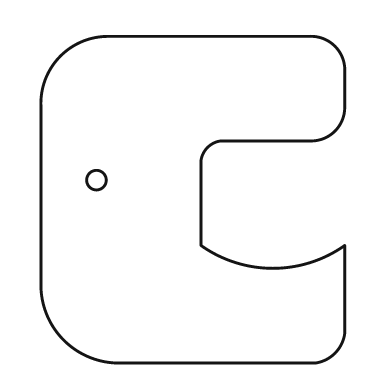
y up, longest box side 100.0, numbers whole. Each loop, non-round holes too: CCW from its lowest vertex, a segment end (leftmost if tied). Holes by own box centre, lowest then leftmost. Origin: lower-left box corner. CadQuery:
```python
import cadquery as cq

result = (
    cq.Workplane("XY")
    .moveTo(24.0, 0.0)
    .lineTo(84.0, 0.0)
    .threePointArc((90.0, 3.0), (93.0, 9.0))
    .lineTo(93.0, 36.0)
    .threePointArc((71.0, 29.0), (49.0, 36.0))
    .lineTo(49.0, 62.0)
    .threePointArc((51.0, 66.0), (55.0, 68.0))
    .lineTo(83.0, 68.0)
    .threePointArc((90.0, 71.0), (93.0, 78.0))
    .lineTo(93.0, 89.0)
    .threePointArc((90.0, 97.0), (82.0, 100.0))
    .lineTo(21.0, 100.0)
    .threePointArc((6.0, 94.0), (0.0, 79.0))
    .lineTo(0.0, 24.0)
    .threePointArc((7.0, 7.0), (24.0, 0.0))
    .close()
    .moveTo(17.0, 56.0)
    .circle(3.0)
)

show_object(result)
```